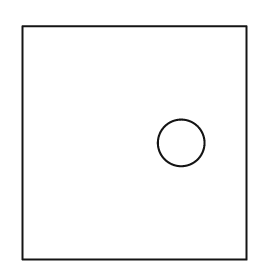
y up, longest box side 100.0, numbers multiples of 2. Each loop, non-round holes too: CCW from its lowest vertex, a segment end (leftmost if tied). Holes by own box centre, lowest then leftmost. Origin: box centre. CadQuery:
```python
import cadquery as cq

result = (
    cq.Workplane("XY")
    .moveTo(-48.0, -50.0)
    .lineTo(48.0, -50.0)
    .lineTo(48.0, 50.0)
    .lineTo(-48.0, 50.0)
    .close()
    .moveTo(20.0, 0.0)
    .circle(10.0)
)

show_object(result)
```